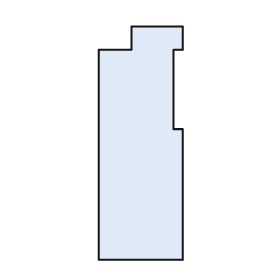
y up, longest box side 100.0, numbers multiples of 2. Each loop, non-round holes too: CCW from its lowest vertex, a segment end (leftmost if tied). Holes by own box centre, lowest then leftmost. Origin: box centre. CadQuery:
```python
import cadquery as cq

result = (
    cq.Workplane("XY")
    .moveTo(-18.0, -50.0)
    .lineTo(18.0, -50.0)
    .lineTo(18.0, 6.0)
    .lineTo(14.0, 6.0)
    .lineTo(14.0, 40.0)
    .lineTo(18.0, 40.0)
    .lineTo(18.0, 50.0)
    .lineTo(-4.0, 50.0)
    .lineTo(-4.0, 40.0)
    .lineTo(-18.0, 40.0)
    .close()
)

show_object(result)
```